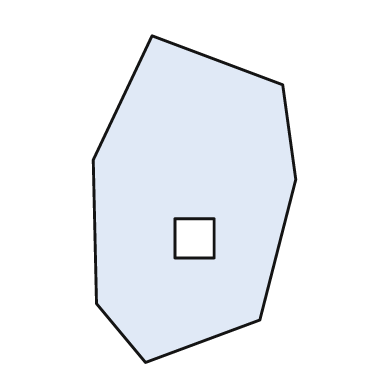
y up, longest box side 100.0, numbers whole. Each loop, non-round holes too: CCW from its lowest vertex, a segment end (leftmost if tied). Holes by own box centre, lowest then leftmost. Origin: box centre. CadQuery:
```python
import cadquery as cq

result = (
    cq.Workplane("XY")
    .moveTo(-15.0, -50.0)
    .lineTo(20.0, -37.0)
    .lineTo(31.0, 6.0)
    .lineTo(27.0, 35.0)
    .lineTo(-13.0, 50.0)
    .lineTo(-31.0, 12.0)
    .lineTo(-30.0, -32.0)
    .close()
    .moveTo(-6.0, -18.0)
    .lineTo(6.0, -18.0)
    .lineTo(6.0, -6.0)
    .lineTo(-6.0, -6.0)
    .close()
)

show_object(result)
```